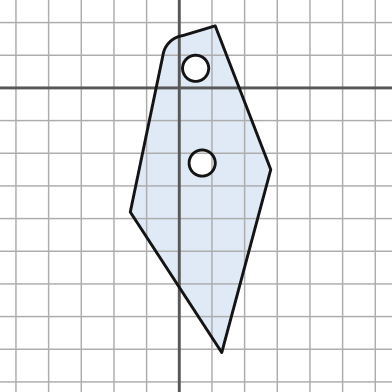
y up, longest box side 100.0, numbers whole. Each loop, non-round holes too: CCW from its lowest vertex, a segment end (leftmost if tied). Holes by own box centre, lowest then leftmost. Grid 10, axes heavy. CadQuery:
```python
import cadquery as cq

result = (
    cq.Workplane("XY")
    .moveTo(13.0, -81.0)
    .lineTo(28.0, -25.0)
    .lineTo(11.0, 19.0)
    .lineTo(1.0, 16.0)
    .threePointArc((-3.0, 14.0), (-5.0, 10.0))
    .lineTo(-15.0, -38.0)
    .close()
    .moveTo(7.0, -23.0)
    .circle(4.0)
    .moveTo(5.0, 6.0)
    .circle(4.0)
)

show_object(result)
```